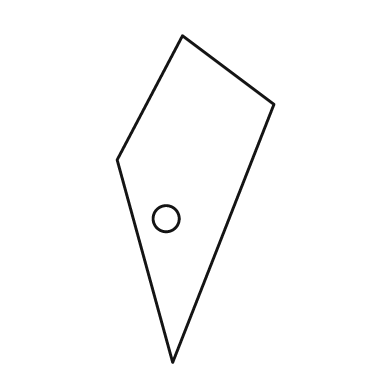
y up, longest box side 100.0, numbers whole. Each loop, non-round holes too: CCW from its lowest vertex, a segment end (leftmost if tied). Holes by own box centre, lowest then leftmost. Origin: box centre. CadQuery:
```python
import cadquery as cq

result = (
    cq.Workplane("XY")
    .moveTo(-7.0, -50.0)
    .lineTo(24.0, 29.0)
    .lineTo(-4.0, 50.0)
    .lineTo(-24.0, 12.0)
    .close()
    .moveTo(-9.0, -6.0)
    .circle(4.0)
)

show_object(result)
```